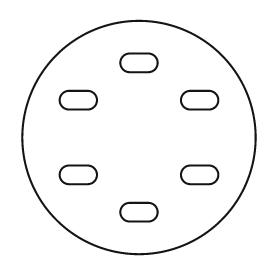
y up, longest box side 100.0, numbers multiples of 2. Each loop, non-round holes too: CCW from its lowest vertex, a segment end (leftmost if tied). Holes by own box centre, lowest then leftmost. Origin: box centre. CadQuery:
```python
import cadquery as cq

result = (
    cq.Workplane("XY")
    .moveTo(0.0, 0.0)
    .circle(50.0)
    .moveTo(-4.0, -36.0)
    .lineTo(4.0, -36.0)
    .threePointArc((8.0, -32.0), (4.0, -28.0))
    .lineTo(-4.0, -28.0)
    .threePointArc((-8.0, -32.0), (-4.0, -36.0))
    .close()
    .moveTo(-30.0, -20.0)
    .lineTo(-22.0, -20.0)
    .threePointArc((-18.0, -16.0), (-22.0, -12.0))
    .lineTo(-30.0, -12.0)
    .threePointArc((-34.0, -16.0), (-30.0, -20.0))
    .close()
    .moveTo(22.0, -20.0)
    .lineTo(30.0, -20.0)
    .threePointArc((34.0, -16.0), (30.0, -12.0))
    .lineTo(22.0, -12.0)
    .threePointArc((18.0, -16.0), (22.0, -20.0))
    .close()
    .moveTo(-30.0, 12.0)
    .lineTo(-22.0, 12.0)
    .threePointArc((-18.0, 16.0), (-22.0, 20.0))
    .lineTo(-30.0, 20.0)
    .threePointArc((-34.0, 16.0), (-30.0, 12.0))
    .close()
    .moveTo(22.0, 12.0)
    .lineTo(30.0, 12.0)
    .threePointArc((34.0, 16.0), (30.0, 20.0))
    .lineTo(22.0, 20.0)
    .threePointArc((18.0, 16.0), (22.0, 12.0))
    .close()
    .moveTo(-4.0, 28.0)
    .lineTo(4.0, 28.0)
    .threePointArc((8.0, 32.0), (4.0, 36.0))
    .lineTo(-4.0, 36.0)
    .threePointArc((-8.0, 32.0), (-4.0, 28.0))
    .close()
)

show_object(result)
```